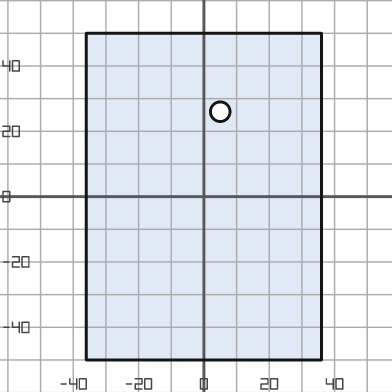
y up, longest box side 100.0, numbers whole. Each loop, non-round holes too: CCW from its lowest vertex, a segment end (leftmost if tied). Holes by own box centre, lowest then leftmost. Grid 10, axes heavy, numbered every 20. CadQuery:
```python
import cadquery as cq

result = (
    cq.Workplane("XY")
    .moveTo(-36.0, -50.0)
    .lineTo(36.0, -50.0)
    .lineTo(36.0, 50.0)
    .lineTo(-36.0, 50.0)
    .close()
    .moveTo(5.0, 26.0)
    .circle(3.0)
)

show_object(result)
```